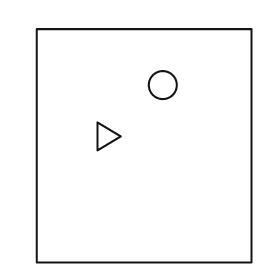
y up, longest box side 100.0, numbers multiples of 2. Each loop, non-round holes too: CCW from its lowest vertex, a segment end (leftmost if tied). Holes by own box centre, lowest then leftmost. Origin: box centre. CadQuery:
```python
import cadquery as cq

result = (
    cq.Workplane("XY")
    .moveTo(-46.0, -50.0)
    .lineTo(46.0, -50.0)
    .lineTo(46.0, 50.0)
    .lineTo(-46.0, 50.0)
    .close()
    .moveTo(-20.0, -2.0)
    .lineTo(-10.0, 4.0)
    .lineTo(-20.0, 10.0)
    .close()
    .moveTo(8.0, 26.0)
    .circle(6.0)
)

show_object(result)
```